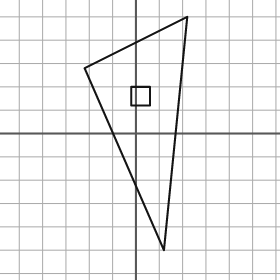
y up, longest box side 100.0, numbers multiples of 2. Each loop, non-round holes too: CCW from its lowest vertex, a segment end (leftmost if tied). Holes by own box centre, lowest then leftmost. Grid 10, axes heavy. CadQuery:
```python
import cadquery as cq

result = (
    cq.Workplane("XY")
    .moveTo(12.0, -50.0)
    .lineTo(22.0, 50.0)
    .lineTo(-22.0, 28.0)
    .close()
    .moveTo(-2.0, 12.0)
    .lineTo(6.0, 12.0)
    .lineTo(6.0, 20.0)
    .lineTo(-2.0, 20.0)
    .close()
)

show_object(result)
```